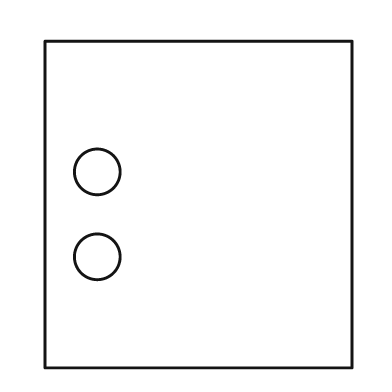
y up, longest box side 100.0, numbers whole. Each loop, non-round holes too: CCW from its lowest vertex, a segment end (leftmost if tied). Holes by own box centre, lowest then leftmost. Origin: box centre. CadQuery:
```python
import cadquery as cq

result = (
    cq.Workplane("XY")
    .moveTo(-47.0, -50.0)
    .lineTo(47.0, -50.0)
    .lineTo(47.0, 50.0)
    .lineTo(-47.0, 50.0)
    .close()
    .moveTo(-31.0, -16.0)
    .circle(7.0)
    .moveTo(-31.0, 10.0)
    .circle(7.0)
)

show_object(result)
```